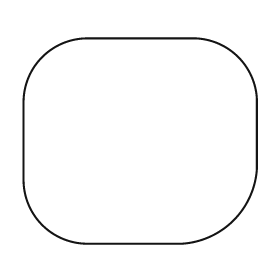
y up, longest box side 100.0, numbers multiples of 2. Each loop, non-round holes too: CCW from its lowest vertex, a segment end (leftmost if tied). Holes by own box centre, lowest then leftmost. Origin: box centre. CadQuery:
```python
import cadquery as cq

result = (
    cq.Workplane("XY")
    .moveTo(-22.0, -44.0)
    .lineTo(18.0, -44.0)
    .threePointArc((40.0, -34.0), (50.0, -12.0))
    .lineTo(50.0, 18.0)
    .threePointArc((42.0, 36.0), (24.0, 44.0))
    .lineTo(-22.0, 44.0)
    .threePointArc((-42.0, 36.0), (-50.0, 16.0))
    .lineTo(-50.0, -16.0)
    .threePointArc((-42.0, -36.0), (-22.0, -44.0))
    .close()
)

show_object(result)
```